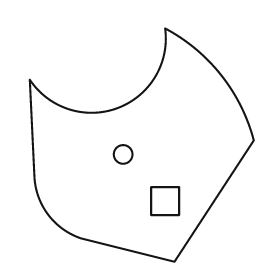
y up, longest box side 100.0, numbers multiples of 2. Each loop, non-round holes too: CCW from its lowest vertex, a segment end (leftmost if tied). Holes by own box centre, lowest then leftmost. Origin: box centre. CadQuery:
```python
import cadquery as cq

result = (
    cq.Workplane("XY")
    .moveTo(14.0, -50.0)
    .lineTo(48.0, 2.0)
    .threePointArc((34.0, 30.0), (10.0, 50.0))
    .threePointArc((-10.0, 16.0), (-48.0, 28.0))
    .lineTo(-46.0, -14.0)
    .threePointArc((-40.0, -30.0), (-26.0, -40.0))
    .close()
    .moveTo(4.0, -30.0)
    .lineTo(16.0, -30.0)
    .lineTo(16.0, -18.0)
    .lineTo(4.0, -18.0)
    .close()
    .moveTo(-8.0, -4.0)
    .circle(4.0)
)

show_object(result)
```